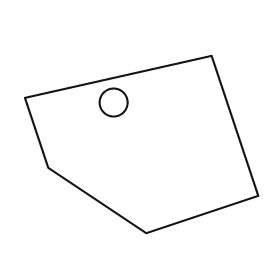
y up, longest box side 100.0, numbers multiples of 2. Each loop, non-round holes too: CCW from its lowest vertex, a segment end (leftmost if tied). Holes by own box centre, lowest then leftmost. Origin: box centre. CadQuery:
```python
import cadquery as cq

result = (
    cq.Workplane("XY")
    .moveTo(2.0, -38.0)
    .lineTo(50.0, -22.0)
    .lineTo(30.0, 38.0)
    .lineTo(-50.0, 20.0)
    .lineTo(-40.0, -10.0)
    .close()
    .moveTo(-12.0, 18.0)
    .circle(6.0)
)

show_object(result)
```